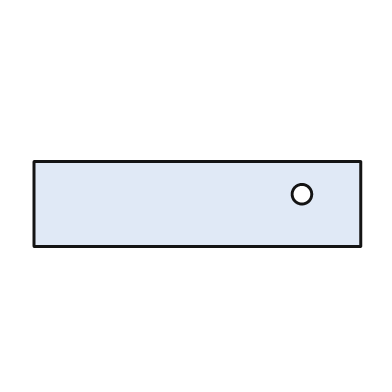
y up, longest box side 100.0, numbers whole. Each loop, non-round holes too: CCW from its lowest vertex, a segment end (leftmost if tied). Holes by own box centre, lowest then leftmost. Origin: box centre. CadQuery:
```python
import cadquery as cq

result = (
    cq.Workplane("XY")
    .moveTo(-50.0, -13.0)
    .lineTo(50.0, -13.0)
    .lineTo(50.0, 13.0)
    .lineTo(-50.0, 13.0)
    .close()
    .moveTo(32.0, 3.0)
    .circle(3.0)
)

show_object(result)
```